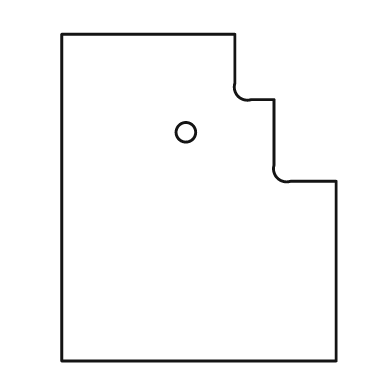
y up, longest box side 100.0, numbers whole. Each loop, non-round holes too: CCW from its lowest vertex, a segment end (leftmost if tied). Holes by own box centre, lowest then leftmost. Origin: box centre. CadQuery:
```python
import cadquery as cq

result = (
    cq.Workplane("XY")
    .moveTo(-42.0, -50.0)
    .lineTo(42.0, -50.0)
    .lineTo(42.0, 5.0)
    .lineTo(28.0, 5.0)
    .threePointArc((24.0, 6.0), (23.0, 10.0))
    .lineTo(23.0, 30.0)
    .lineTo(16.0, 30.0)
    .threePointArc((12.0, 31.0), (11.0, 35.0))
    .lineTo(11.0, 50.0)
    .lineTo(-42.0, 50.0)
    .close()
    .moveTo(-4.0, 20.0)
    .circle(3.0)
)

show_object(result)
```